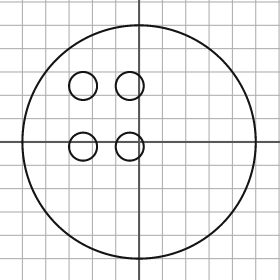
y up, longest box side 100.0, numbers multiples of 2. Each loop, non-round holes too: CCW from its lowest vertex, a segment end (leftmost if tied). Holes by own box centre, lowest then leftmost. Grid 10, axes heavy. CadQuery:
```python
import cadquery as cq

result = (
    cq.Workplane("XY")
    .moveTo(0.0, 0.0)
    .circle(50.0)
    .moveTo(-24.0, -2.0)
    .circle(6.0)
    .moveTo(-4.0, -2.0)
    .circle(6.0)
    .moveTo(-24.0, 24.0)
    .circle(6.0)
    .moveTo(-4.0, 24.0)
    .circle(6.0)
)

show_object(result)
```